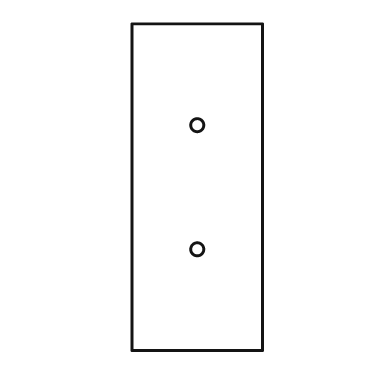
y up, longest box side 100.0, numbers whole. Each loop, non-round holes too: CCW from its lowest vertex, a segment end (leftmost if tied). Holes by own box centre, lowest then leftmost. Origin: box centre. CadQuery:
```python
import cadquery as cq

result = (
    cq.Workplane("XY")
    .moveTo(-20.0, -50.0)
    .lineTo(20.0, -50.0)
    .lineTo(20.0, 50.0)
    .lineTo(-20.0, 50.0)
    .close()
    .moveTo(0.0, -19.0)
    .circle(2.0)
    .moveTo(0.0, 19.0)
    .circle(2.0)
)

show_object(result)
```